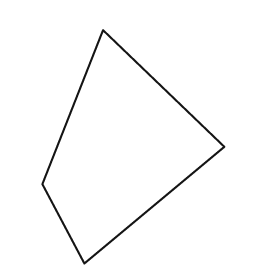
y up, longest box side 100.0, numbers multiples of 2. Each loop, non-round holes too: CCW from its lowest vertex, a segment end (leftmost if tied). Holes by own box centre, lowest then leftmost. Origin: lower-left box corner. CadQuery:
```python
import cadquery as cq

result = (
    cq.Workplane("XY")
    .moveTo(18.0, 0.0)
    .lineTo(78.0, 50.0)
    .lineTo(26.0, 100.0)
    .lineTo(0.0, 34.0)
    .close()
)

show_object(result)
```